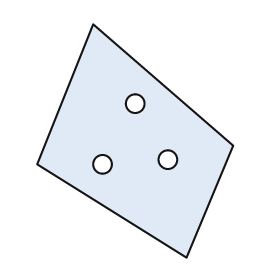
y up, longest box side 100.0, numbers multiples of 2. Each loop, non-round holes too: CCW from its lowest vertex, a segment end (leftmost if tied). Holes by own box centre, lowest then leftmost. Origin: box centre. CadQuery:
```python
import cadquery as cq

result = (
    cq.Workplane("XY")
    .moveTo(22.0, -50.0)
    .lineTo(42.0, -2.0)
    .lineTo(-18.0, 50.0)
    .lineTo(-42.0, -10.0)
    .close()
    .moveTo(-14.0, -10.0)
    .circle(4.0)
    .moveTo(14.0, -8.0)
    .circle(4.0)
    .moveTo(0.0, 16.0)
    .circle(4.0)
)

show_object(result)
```